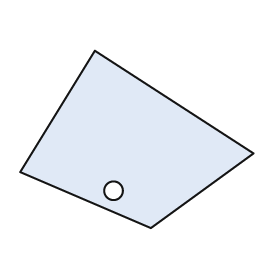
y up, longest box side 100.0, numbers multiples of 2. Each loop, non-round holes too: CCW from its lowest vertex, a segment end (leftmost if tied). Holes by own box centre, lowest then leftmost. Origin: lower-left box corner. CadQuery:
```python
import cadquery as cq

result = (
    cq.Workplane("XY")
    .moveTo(56.0, 0.0)
    .lineTo(100.0, 32.0)
    .lineTo(32.0, 76.0)
    .lineTo(0.0, 24.0)
    .close()
    .moveTo(40.0, 16.0)
    .circle(4.0)
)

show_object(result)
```